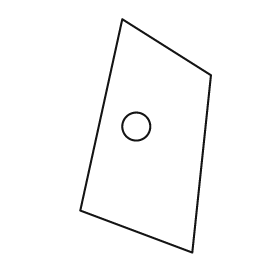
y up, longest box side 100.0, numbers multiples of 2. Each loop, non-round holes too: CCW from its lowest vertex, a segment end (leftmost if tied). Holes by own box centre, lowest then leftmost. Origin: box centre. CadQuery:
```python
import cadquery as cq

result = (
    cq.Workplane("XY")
    .moveTo(20.0, -50.0)
    .lineTo(28.0, 26.0)
    .lineTo(-10.0, 50.0)
    .lineTo(-28.0, -32.0)
    .close()
    .moveTo(-4.0, 4.0)
    .circle(6.0)
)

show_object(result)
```